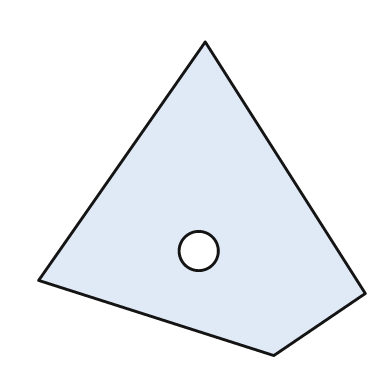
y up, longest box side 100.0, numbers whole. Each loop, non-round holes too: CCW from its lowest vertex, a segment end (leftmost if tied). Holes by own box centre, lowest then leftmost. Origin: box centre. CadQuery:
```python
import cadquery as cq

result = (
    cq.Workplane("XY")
    .moveTo(22.0, -48.0)
    .lineTo(50.0, -29.0)
    .lineTo(1.0, 48.0)
    .lineTo(-50.0, -25.0)
    .close()
    .moveTo(-1.0, -16.0)
    .circle(6.0)
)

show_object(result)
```